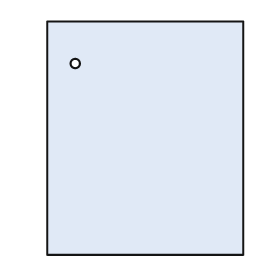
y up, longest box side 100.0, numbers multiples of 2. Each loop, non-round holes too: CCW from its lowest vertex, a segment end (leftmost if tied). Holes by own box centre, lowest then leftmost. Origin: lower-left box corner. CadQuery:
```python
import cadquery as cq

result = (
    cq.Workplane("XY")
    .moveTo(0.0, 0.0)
    .lineTo(84.0, 0.0)
    .lineTo(84.0, 100.0)
    .lineTo(0.0, 100.0)
    .close()
    .moveTo(12.0, 82.0)
    .circle(2.0)
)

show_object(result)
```